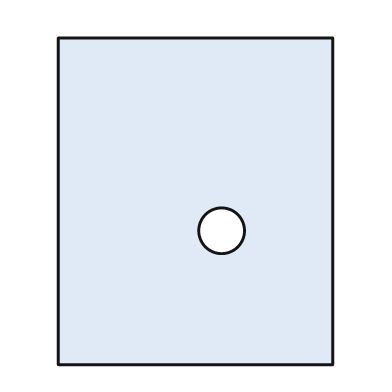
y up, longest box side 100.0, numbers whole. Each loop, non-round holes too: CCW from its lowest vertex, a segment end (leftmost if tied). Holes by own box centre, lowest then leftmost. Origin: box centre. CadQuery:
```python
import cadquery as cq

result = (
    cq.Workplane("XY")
    .moveTo(-42.0, -50.0)
    .lineTo(42.0, -50.0)
    .lineTo(42.0, 50.0)
    .lineTo(-42.0, 50.0)
    .close()
    .moveTo(8.0, -9.0)
    .circle(7.0)
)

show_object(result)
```